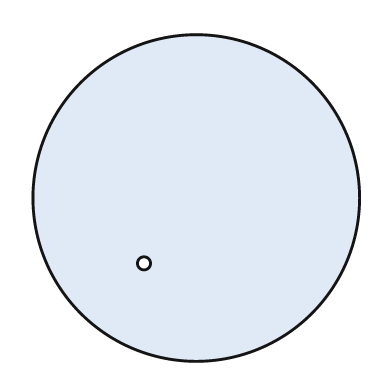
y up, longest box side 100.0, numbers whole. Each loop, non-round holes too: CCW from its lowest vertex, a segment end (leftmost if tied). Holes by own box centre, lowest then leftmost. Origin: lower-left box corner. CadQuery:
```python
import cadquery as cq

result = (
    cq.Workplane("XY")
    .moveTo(50.0, 50.0)
    .circle(50.0)
    .moveTo(34.0, 30.0)
    .circle(2.0)
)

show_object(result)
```